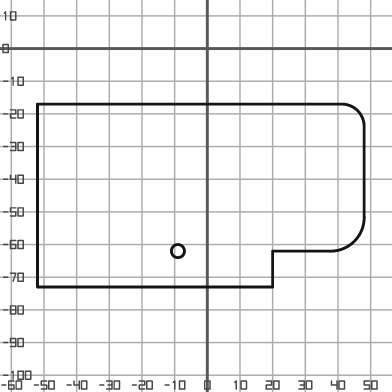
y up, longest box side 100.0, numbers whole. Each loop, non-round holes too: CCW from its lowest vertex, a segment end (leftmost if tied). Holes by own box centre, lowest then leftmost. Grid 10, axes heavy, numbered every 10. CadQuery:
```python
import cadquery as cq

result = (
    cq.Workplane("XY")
    .moveTo(-52.0, -73.0)
    .lineTo(20.0, -73.0)
    .lineTo(20.0, -62.0)
    .lineTo(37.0, -62.0)
    .threePointArc((45.0, -59.0), (48.0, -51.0))
    .lineTo(48.0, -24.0)
    .threePointArc((46.0, -19.0), (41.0, -17.0))
    .lineTo(-52.0, -17.0)
    .close()
    .moveTo(-9.0, -62.0)
    .circle(2.0)
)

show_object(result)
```